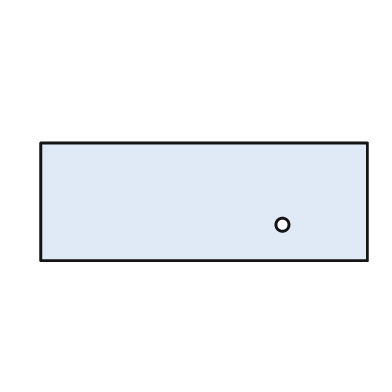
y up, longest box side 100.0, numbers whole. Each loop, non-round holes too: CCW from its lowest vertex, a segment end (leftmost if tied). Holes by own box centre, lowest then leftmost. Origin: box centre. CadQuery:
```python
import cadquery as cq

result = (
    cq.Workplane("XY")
    .moveTo(-50.0, -18.0)
    .lineTo(50.0, -18.0)
    .lineTo(50.0, 18.0)
    .lineTo(-50.0, 18.0)
    .close()
    .moveTo(24.0, -7.0)
    .circle(2.0)
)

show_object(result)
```